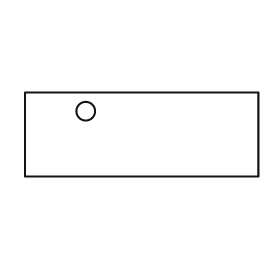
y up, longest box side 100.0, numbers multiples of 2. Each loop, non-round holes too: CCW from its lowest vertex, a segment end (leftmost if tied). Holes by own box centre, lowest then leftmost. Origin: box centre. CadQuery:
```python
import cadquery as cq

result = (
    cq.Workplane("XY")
    .moveTo(-50.0, -18.0)
    .lineTo(50.0, -18.0)
    .lineTo(50.0, 18.0)
    .lineTo(-50.0, 18.0)
    .close()
    .moveTo(-24.0, 10.0)
    .circle(4.0)
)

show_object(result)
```